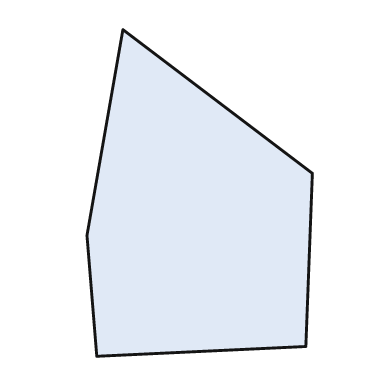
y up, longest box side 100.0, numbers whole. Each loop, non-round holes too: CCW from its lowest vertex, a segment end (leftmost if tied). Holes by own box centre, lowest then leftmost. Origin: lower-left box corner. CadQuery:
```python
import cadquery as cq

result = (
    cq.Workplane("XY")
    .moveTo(3.0, 0.0)
    .lineTo(67.0, 3.0)
    .lineTo(69.0, 56.0)
    .lineTo(11.0, 100.0)
    .lineTo(0.0, 37.0)
    .close()
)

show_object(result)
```